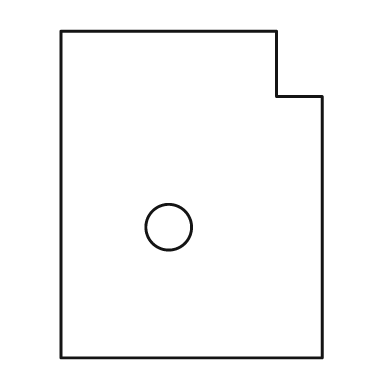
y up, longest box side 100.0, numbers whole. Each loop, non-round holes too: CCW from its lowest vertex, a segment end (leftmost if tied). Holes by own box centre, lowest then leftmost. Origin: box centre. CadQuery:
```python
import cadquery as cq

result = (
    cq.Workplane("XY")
    .moveTo(-40.0, -50.0)
    .lineTo(40.0, -50.0)
    .lineTo(40.0, 30.0)
    .lineTo(26.0, 30.0)
    .lineTo(26.0, 50.0)
    .lineTo(-40.0, 50.0)
    .close()
    .moveTo(-7.0, -10.0)
    .circle(7.0)
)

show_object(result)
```